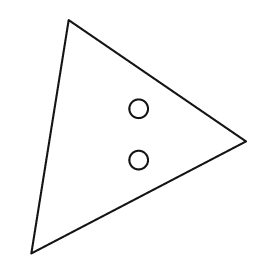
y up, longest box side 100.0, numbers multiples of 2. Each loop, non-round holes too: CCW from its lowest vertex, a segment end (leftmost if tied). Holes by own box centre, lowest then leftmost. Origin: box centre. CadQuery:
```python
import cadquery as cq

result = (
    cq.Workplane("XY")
    .moveTo(-46.0, -50.0)
    .lineTo(46.0, -2.0)
    .lineTo(-30.0, 50.0)
    .close()
    .moveTo(0.0, -10.0)
    .circle(4.0)
    .moveTo(0.0, 12.0)
    .circle(4.0)
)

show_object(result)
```